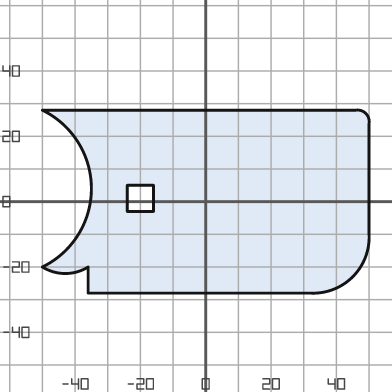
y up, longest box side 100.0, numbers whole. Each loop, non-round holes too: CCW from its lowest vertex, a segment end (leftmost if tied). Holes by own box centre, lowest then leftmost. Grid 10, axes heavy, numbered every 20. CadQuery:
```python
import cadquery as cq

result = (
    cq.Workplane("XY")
    .moveTo(-36.0, -28.0)
    .lineTo(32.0, -28.0)
    .threePointArc((45.0, -23.0), (50.0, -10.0))
    .lineTo(50.0, 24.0)
    .threePointArc((49.0, 27.0), (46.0, 28.0))
    .lineTo(-50.0, 28.0)
    .threePointArc((-35.0, 4.0), (-50.0, -20.0))
    .threePointArc((-43.0, -22.0), (-36.0, -20.0))
    .close()
    .moveTo(-24.0, -3.0)
    .lineTo(-16.0, -3.0)
    .lineTo(-16.0, 5.0)
    .lineTo(-24.0, 5.0)
    .close()
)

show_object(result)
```